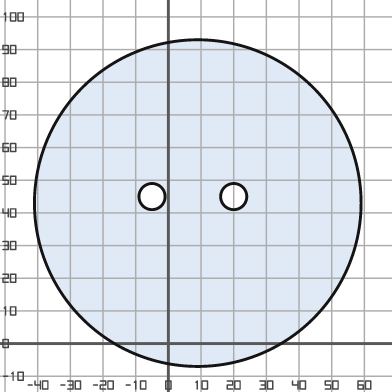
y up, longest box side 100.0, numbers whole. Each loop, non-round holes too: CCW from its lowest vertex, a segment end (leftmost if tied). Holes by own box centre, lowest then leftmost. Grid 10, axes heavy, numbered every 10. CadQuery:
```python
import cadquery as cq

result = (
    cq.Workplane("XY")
    .moveTo(9.0, 43.0)
    .circle(50.0)
    .moveTo(-5.0, 45.0)
    .circle(4.0)
    .moveTo(20.0, 45.0)
    .circle(4.0)
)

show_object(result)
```